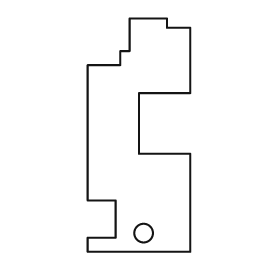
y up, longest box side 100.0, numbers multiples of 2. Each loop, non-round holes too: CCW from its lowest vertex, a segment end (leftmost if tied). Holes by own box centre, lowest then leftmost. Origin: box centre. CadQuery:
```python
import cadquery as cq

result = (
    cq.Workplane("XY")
    .moveTo(-22.0, -50.0)
    .lineTo(22.0, -50.0)
    .lineTo(22.0, -8.0)
    .lineTo(0.0, -8.0)
    .lineTo(0.0, 18.0)
    .lineTo(22.0, 18.0)
    .lineTo(22.0, 46.0)
    .lineTo(12.0, 46.0)
    .lineTo(12.0, 50.0)
    .lineTo(-4.0, 50.0)
    .lineTo(-4.0, 36.0)
    .lineTo(-8.0, 36.0)
    .lineTo(-8.0, 30.0)
    .lineTo(-22.0, 30.0)
    .lineTo(-22.0, -28.0)
    .lineTo(-10.0, -28.0)
    .lineTo(-10.0, -44.0)
    .lineTo(-22.0, -44.0)
    .close()
    .moveTo(2.0, -42.0)
    .circle(4.0)
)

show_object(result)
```